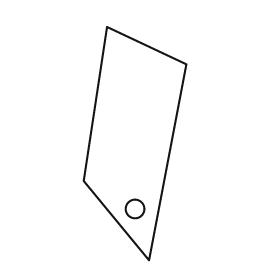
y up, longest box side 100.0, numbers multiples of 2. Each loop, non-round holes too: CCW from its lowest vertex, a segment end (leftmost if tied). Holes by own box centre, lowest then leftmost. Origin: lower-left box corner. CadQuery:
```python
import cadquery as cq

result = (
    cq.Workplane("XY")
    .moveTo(28.0, 0.0)
    .lineTo(44.0, 84.0)
    .lineTo(10.0, 100.0)
    .lineTo(0.0, 34.0)
    .close()
    .moveTo(22.0, 22.0)
    .circle(4.0)
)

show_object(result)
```